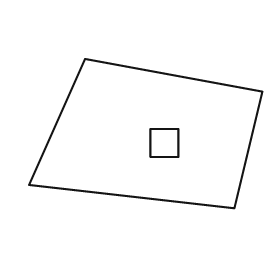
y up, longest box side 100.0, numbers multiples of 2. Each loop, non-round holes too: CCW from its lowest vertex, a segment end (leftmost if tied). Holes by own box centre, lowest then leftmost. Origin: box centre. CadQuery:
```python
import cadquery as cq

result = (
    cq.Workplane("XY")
    .moveTo(38.0, -32.0)
    .lineTo(50.0, 18.0)
    .lineTo(-26.0, 32.0)
    .lineTo(-50.0, -22.0)
    .close()
    .moveTo(2.0, -10.0)
    .lineTo(14.0, -10.0)
    .lineTo(14.0, 2.0)
    .lineTo(2.0, 2.0)
    .close()
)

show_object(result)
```